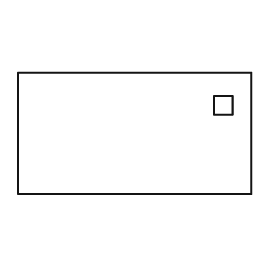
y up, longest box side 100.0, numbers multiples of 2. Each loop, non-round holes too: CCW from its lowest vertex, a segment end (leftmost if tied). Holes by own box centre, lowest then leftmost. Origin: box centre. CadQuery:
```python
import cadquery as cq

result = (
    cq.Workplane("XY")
    .moveTo(-50.0, -26.0)
    .lineTo(50.0, -26.0)
    .lineTo(50.0, 26.0)
    .lineTo(-50.0, 26.0)
    .close()
    .moveTo(34.0, 8.0)
    .lineTo(42.0, 8.0)
    .lineTo(42.0, 16.0)
    .lineTo(34.0, 16.0)
    .close()
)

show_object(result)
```